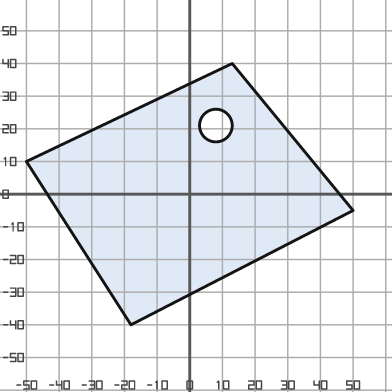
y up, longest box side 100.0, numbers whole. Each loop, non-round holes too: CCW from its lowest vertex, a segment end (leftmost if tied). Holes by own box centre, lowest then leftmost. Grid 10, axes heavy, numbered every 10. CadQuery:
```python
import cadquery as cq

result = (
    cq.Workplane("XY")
    .moveTo(-18.0, -40.0)
    .lineTo(50.0, -5.0)
    .lineTo(13.0, 40.0)
    .lineTo(-50.0, 10.0)
    .close()
    .moveTo(8.0, 21.0)
    .circle(5.0)
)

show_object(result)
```